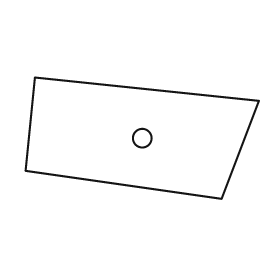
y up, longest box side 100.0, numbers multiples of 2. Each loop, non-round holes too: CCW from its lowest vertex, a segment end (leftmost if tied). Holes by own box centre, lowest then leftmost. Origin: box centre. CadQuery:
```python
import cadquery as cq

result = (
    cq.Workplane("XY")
    .moveTo(34.0, -26.0)
    .lineTo(50.0, 16.0)
    .lineTo(-46.0, 26.0)
    .lineTo(-50.0, -14.0)
    .close()
    .moveTo(0.0, 0.0)
    .circle(4.0)
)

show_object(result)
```